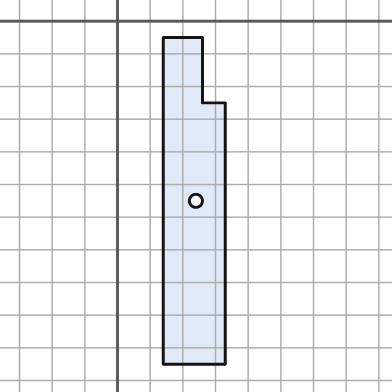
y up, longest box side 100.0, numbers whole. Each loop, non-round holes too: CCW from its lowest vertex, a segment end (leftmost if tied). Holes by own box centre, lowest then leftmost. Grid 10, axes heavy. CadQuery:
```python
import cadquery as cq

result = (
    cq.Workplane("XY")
    .moveTo(14.0, -105.0)
    .lineTo(33.0, -105.0)
    .lineTo(33.0, -25.0)
    .lineTo(26.0, -25.0)
    .lineTo(26.0, -5.0)
    .lineTo(14.0, -5.0)
    .close()
    .moveTo(24.0, -55.0)
    .circle(2.0)
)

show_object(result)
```